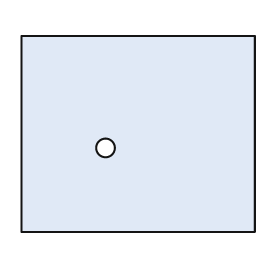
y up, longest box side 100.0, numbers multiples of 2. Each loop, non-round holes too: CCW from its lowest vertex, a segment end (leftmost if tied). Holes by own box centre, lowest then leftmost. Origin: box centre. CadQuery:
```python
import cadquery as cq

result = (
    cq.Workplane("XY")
    .moveTo(-50.0, -42.0)
    .lineTo(50.0, -42.0)
    .lineTo(50.0, 42.0)
    .lineTo(-50.0, 42.0)
    .close()
    .moveTo(-14.0, -6.0)
    .circle(4.0)
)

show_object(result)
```